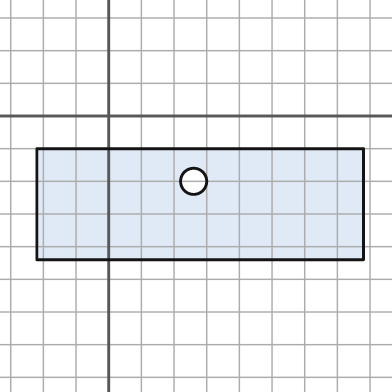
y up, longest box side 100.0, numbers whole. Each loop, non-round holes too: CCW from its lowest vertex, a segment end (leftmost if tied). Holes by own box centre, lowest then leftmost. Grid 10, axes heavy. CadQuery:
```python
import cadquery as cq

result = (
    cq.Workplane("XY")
    .moveTo(-22.0, -44.0)
    .lineTo(78.0, -44.0)
    .lineTo(78.0, -10.0)
    .lineTo(-22.0, -10.0)
    .close()
    .moveTo(26.0, -20.0)
    .circle(4.0)
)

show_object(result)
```